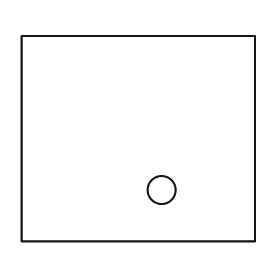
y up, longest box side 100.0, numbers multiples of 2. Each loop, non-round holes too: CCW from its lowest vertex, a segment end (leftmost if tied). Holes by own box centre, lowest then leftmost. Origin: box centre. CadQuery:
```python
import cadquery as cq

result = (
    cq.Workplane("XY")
    .moveTo(-50.0, -44.0)
    .lineTo(50.0, -44.0)
    .lineTo(50.0, 44.0)
    .lineTo(-50.0, 44.0)
    .close()
    .moveTo(10.0, -22.0)
    .circle(6.0)
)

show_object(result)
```